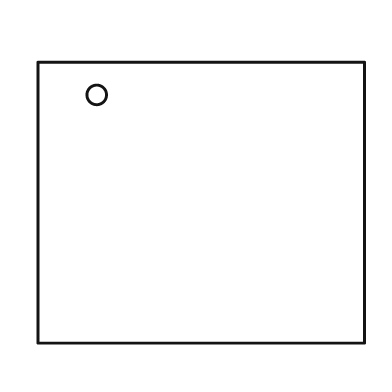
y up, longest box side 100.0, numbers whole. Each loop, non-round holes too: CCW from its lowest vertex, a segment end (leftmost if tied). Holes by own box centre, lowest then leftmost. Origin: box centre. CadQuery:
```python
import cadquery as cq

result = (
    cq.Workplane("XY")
    .moveTo(-50.0, -43.0)
    .lineTo(50.0, -43.0)
    .lineTo(50.0, 43.0)
    .lineTo(-50.0, 43.0)
    .close()
    .moveTo(-32.0, 33.0)
    .circle(3.0)
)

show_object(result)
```